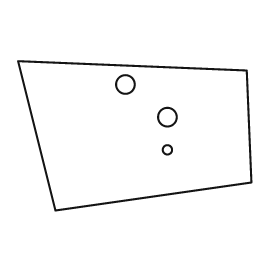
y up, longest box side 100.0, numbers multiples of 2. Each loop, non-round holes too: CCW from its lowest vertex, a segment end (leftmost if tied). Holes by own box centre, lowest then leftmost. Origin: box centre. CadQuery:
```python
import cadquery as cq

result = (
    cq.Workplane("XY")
    .moveTo(-34.0, -32.0)
    .lineTo(50.0, -20.0)
    .lineTo(48.0, 28.0)
    .lineTo(-50.0, 32.0)
    .close()
    .moveTo(14.0, -6.0)
    .circle(2.0)
    .moveTo(14.0, 8.0)
    .circle(4.0)
    .moveTo(-4.0, 22.0)
    .circle(4.0)
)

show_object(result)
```